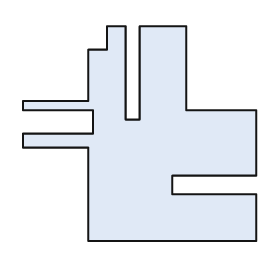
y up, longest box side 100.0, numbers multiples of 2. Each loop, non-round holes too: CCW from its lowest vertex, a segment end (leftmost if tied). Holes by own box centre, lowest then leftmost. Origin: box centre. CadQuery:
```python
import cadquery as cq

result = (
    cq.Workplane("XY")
    .moveTo(-22.0, -46.0)
    .lineTo(50.0, -46.0)
    .lineTo(50.0, -26.0)
    .lineTo(14.0, -26.0)
    .lineTo(14.0, -18.0)
    .lineTo(50.0, -18.0)
    .lineTo(50.0, 10.0)
    .lineTo(20.0, 10.0)
    .lineTo(20.0, 46.0)
    .lineTo(0.0, 46.0)
    .lineTo(0.0, 6.0)
    .lineTo(-6.0, 6.0)
    .lineTo(-6.0, 46.0)
    .lineTo(-14.0, 46.0)
    .lineTo(-14.0, 36.0)
    .lineTo(-22.0, 36.0)
    .lineTo(-22.0, 14.0)
    .lineTo(-50.0, 14.0)
    .lineTo(-50.0, 10.0)
    .lineTo(-20.0, 10.0)
    .lineTo(-20.0, 0.0)
    .lineTo(-50.0, 0.0)
    .lineTo(-50.0, -6.0)
    .lineTo(-22.0, -6.0)
    .close()
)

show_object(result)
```